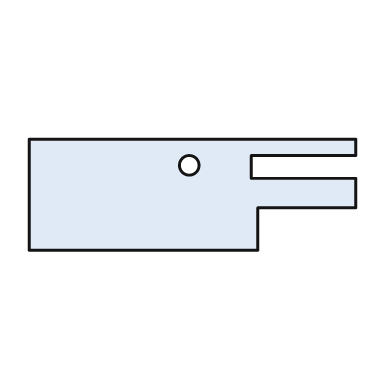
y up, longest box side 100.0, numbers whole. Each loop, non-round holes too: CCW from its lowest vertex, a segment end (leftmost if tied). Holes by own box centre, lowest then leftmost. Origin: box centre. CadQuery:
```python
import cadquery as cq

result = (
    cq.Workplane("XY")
    .moveTo(-50.0, -17.0)
    .lineTo(20.0, -17.0)
    .lineTo(20.0, -4.0)
    .lineTo(50.0, -4.0)
    .lineTo(50.0, 5.0)
    .lineTo(18.0, 5.0)
    .lineTo(18.0, 12.0)
    .lineTo(50.0, 12.0)
    .lineTo(50.0, 17.0)
    .lineTo(-50.0, 17.0)
    .close()
    .moveTo(-1.0, 9.0)
    .circle(3.0)
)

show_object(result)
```